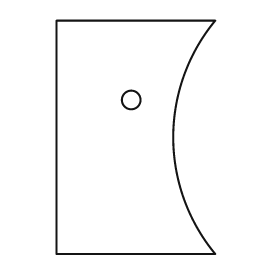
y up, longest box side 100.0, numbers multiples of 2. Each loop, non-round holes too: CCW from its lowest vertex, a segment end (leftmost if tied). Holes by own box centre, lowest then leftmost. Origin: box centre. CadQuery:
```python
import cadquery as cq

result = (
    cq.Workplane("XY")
    .moveTo(-34.0, -50.0)
    .lineTo(34.0, -50.0)
    .threePointArc((16.0, 0.0), (34.0, 50.0))
    .lineTo(-34.0, 50.0)
    .close()
    .moveTo(-2.0, 16.0)
    .circle(4.0)
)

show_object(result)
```